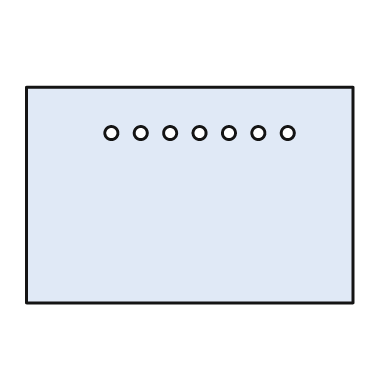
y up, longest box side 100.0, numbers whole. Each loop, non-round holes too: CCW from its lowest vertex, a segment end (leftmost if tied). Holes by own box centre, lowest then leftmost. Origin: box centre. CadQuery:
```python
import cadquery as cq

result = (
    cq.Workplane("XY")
    .moveTo(-50.0, -33.0)
    .lineTo(50.0, -33.0)
    .lineTo(50.0, 33.0)
    .lineTo(-50.0, 33.0)
    .close()
    .moveTo(-24.0, 19.0)
    .circle(2.0)
    .moveTo(-15.0, 19.0)
    .circle(2.0)
    .moveTo(-6.0, 19.0)
    .circle(2.0)
    .moveTo(3.0, 19.0)
    .circle(2.0)
    .moveTo(12.0, 19.0)
    .circle(2.0)
    .moveTo(21.0, 19.0)
    .circle(2.0)
    .moveTo(30.0, 19.0)
    .circle(2.0)
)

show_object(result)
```